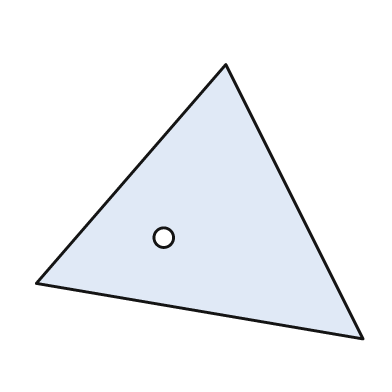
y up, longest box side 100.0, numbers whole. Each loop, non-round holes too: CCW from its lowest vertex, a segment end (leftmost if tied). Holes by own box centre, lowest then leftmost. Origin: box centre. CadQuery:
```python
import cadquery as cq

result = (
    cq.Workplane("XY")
    .moveTo(50.0, -42.0)
    .lineTo(8.0, 42.0)
    .lineTo(-50.0, -25.0)
    .close()
    .moveTo(-11.0, -11.0)
    .circle(3.0)
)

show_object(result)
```